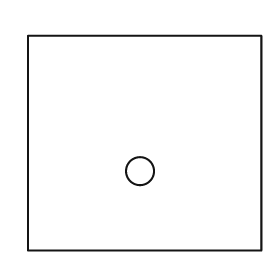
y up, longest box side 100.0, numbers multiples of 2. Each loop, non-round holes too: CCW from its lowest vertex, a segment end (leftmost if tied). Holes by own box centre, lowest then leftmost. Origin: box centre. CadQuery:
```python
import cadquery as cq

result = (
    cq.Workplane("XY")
    .moveTo(-50.0, -46.0)
    .lineTo(50.0, -46.0)
    .lineTo(50.0, 46.0)
    .lineTo(-50.0, 46.0)
    .close()
    .moveTo(-2.0, -12.0)
    .circle(6.0)
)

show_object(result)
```